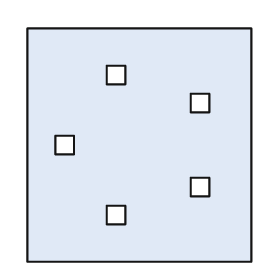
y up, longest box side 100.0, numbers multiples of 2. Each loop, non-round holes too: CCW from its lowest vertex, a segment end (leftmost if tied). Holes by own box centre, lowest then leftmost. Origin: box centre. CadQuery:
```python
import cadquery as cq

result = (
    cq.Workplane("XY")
    .moveTo(-48.0, -50.0)
    .lineTo(48.0, -50.0)
    .lineTo(48.0, 50.0)
    .lineTo(-48.0, 50.0)
    .close()
    .moveTo(-14.0, -34.0)
    .lineTo(-6.0, -34.0)
    .lineTo(-6.0, -26.0)
    .lineTo(-14.0, -26.0)
    .close()
    .moveTo(22.0, -22.0)
    .lineTo(30.0, -22.0)
    .lineTo(30.0, -14.0)
    .lineTo(22.0, -14.0)
    .close()
    .moveTo(-36.0, -4.0)
    .lineTo(-28.0, -4.0)
    .lineTo(-28.0, 4.0)
    .lineTo(-36.0, 4.0)
    .close()
    .moveTo(22.0, 14.0)
    .lineTo(30.0, 14.0)
    .lineTo(30.0, 22.0)
    .lineTo(22.0, 22.0)
    .close()
    .moveTo(-14.0, 26.0)
    .lineTo(-6.0, 26.0)
    .lineTo(-6.0, 34.0)
    .lineTo(-14.0, 34.0)
    .close()
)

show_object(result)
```